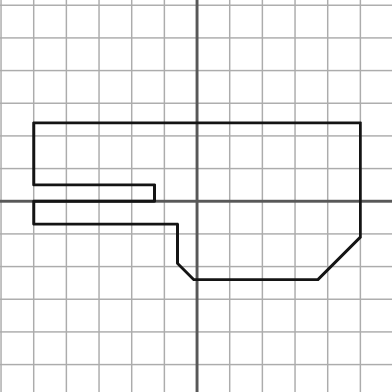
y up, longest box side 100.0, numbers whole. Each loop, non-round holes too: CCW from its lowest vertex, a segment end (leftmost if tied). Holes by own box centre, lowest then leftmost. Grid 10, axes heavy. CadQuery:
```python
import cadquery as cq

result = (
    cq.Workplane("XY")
    .moveTo(-1.0, -24.0)
    .lineTo(37.0, -24.0)
    .lineTo(50.0, -11.0)
    .lineTo(50.0, 24.0)
    .lineTo(-50.0, 24.0)
    .lineTo(-50.0, 5.0)
    .lineTo(-13.0, 5.0)
    .lineTo(-13.0, 0.0)
    .lineTo(-50.0, 0.0)
    .lineTo(-50.0, -7.0)
    .lineTo(-6.0, -7.0)
    .lineTo(-6.0, -19.0)
    .close()
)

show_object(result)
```